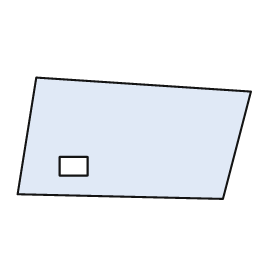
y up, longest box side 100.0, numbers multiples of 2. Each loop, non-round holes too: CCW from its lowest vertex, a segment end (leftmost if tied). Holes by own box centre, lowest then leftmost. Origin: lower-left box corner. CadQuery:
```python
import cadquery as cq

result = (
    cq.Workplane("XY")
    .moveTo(88.0, 0.0)
    .lineTo(100.0, 46.0)
    .lineTo(8.0, 52.0)
    .lineTo(0.0, 2.0)
    .close()
    .moveTo(18.0, 10.0)
    .lineTo(30.0, 10.0)
    .lineTo(30.0, 18.0)
    .lineTo(18.0, 18.0)
    .close()
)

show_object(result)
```